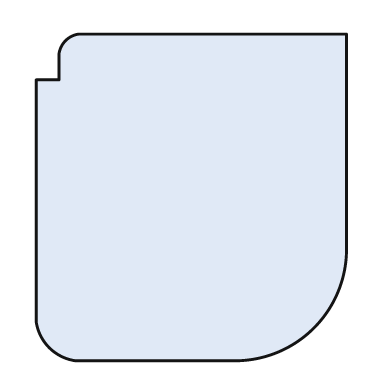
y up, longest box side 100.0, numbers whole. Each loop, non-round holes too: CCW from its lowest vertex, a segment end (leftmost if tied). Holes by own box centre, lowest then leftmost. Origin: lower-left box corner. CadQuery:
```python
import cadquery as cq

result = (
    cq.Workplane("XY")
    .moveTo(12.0, 0.0)
    .lineTo(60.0, 0.0)
    .threePointArc((85.0, 10.0), (95.0, 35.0))
    .lineTo(95.0, 100.0)
    .lineTo(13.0, 100.0)
    .threePointArc((9.0, 98.0), (7.0, 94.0))
    .lineTo(7.0, 86.0)
    .lineTo(0.0, 86.0)
    .lineTo(0.0, 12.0)
    .threePointArc((4.0, 4.0), (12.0, 0.0))
    .close()
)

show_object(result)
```